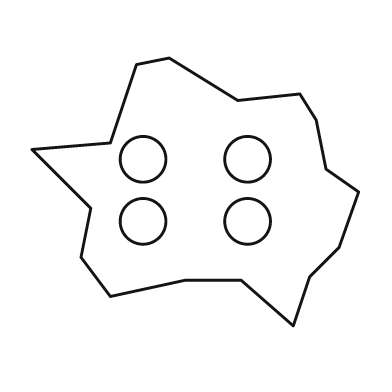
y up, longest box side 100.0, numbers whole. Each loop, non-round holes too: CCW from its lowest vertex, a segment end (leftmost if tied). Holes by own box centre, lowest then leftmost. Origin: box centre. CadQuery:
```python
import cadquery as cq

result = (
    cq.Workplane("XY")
    .moveTo(30.0, -41.0)
    .lineTo(35.0, -26.0)
    .lineTo(44.0, -17.0)
    .lineTo(50.0, 0.0)
    .lineTo(40.0, 7.0)
    .lineTo(37.0, 22.0)
    .lineTo(32.0, 30.0)
    .lineTo(13.0, 28.0)
    .lineTo(-8.0, 41.0)
    .lineTo(-18.0, 39.0)
    .lineTo(-26.0, 15.0)
    .lineTo(-50.0, 13.0)
    .lineTo(-32.0, -5.0)
    .lineTo(-35.0, -20.0)
    .lineTo(-26.0, -32.0)
    .lineTo(-3.0, -27.0)
    .lineTo(14.0, -27.0)
    .close()
    .moveTo(-16.0, -9.0)
    .circle(7.0)
    .moveTo(16.0, -9.0)
    .circle(7.0)
    .moveTo(-16.0, 10.0)
    .circle(7.0)
    .moveTo(16.0, 10.0)
    .circle(7.0)
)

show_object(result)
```